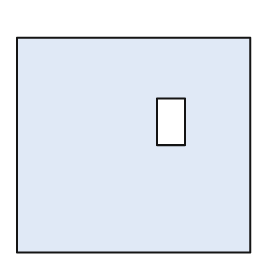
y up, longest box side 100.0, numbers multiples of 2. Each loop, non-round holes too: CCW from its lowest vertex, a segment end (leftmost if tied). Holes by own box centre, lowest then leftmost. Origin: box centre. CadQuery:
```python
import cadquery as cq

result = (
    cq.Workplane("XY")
    .moveTo(-50.0, -46.0)
    .lineTo(50.0, -46.0)
    .lineTo(50.0, 46.0)
    .lineTo(-50.0, 46.0)
    .close()
    .moveTo(10.0, 0.0)
    .lineTo(22.0, 0.0)
    .lineTo(22.0, 20.0)
    .lineTo(10.0, 20.0)
    .close()
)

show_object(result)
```